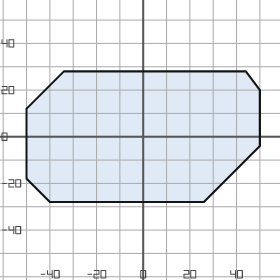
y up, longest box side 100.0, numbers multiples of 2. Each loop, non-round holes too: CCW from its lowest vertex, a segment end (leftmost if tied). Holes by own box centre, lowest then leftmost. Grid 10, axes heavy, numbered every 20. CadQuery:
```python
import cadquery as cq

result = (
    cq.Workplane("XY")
    .moveTo(-40.0, -28.0)
    .lineTo(26.0, -28.0)
    .lineTo(50.0, -4.0)
    .lineTo(50.0, 20.0)
    .lineTo(44.0, 28.0)
    .lineTo(-34.0, 28.0)
    .lineTo(-50.0, 12.0)
    .lineTo(-50.0, -18.0)
    .close()
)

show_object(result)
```